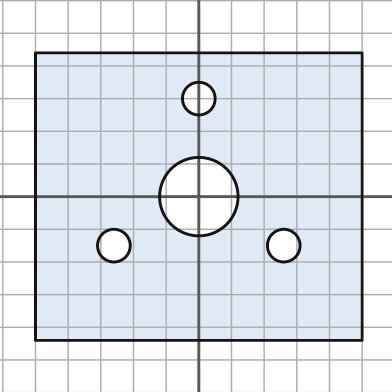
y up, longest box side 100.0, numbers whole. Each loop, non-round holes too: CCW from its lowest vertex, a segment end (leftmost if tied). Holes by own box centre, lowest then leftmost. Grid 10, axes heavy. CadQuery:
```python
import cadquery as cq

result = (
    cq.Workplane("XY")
    .moveTo(-50.0, -44.0)
    .lineTo(50.0, -44.0)
    .lineTo(50.0, 44.0)
    .lineTo(-50.0, 44.0)
    .close()
    .moveTo(-26.0, -15.0)
    .circle(5.0)
    .moveTo(26.0, -15.0)
    .circle(5.0)
    .moveTo(0.0, 0.0)
    .circle(12.0)
    .moveTo(0.0, 30.0)
    .circle(5.0)
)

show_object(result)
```